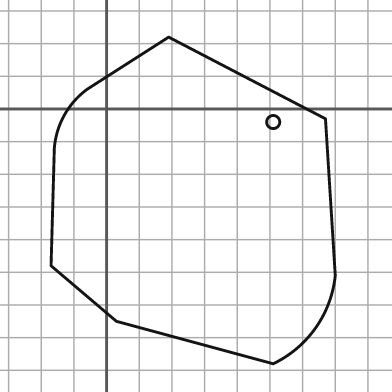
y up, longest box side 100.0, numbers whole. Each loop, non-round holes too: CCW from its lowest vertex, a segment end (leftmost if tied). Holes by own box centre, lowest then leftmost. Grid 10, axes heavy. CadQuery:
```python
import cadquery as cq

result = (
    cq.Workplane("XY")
    .moveTo(51.0, -78.0)
    .threePointArc((64.0, -67.0), (70.0, -51.0))
    .lineTo(67.0, -3.0)
    .lineTo(19.0, 22.0)
    .lineTo(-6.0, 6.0)
    .threePointArc((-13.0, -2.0), (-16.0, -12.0))
    .lineTo(-17.0, -48.0)
    .lineTo(3.0, -65.0)
    .close()
    .moveTo(51.0, -4.0)
    .circle(2.0)
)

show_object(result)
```